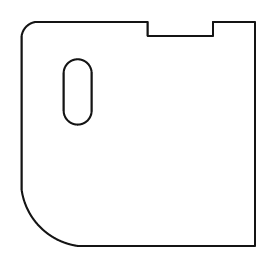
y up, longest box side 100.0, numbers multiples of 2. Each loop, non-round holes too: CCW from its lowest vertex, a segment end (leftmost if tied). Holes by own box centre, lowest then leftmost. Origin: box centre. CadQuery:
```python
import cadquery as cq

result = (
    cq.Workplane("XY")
    .moveTo(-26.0, -48.0)
    .lineTo(50.0, -48.0)
    .lineTo(50.0, 48.0)
    .lineTo(32.0, 48.0)
    .lineTo(32.0, 42.0)
    .lineTo(4.0, 42.0)
    .lineTo(4.0, 48.0)
    .lineTo(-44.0, 48.0)
    .threePointArc((-48.0, 46.0), (-50.0, 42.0))
    .lineTo(-50.0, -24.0)
    .threePointArc((-42.0, -40.0), (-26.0, -48.0))
    .close()
    .moveTo(-32.0, 10.0)
    .threePointArc((-26.0, 4.0), (-20.0, 10.0))
    .lineTo(-20.0, 26.0)
    .threePointArc((-26.0, 32.0), (-32.0, 26.0))
    .close()
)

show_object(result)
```